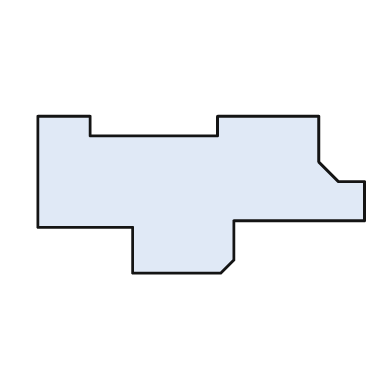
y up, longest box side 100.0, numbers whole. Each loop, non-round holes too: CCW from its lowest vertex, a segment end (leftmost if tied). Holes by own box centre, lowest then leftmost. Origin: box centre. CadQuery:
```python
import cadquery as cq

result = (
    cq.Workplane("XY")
    .moveTo(-21.0, -24.0)
    .lineTo(6.0, -24.0)
    .lineTo(10.0, -20.0)
    .lineTo(10.0, -8.0)
    .lineTo(50.0, -8.0)
    .lineTo(50.0, 4.0)
    .lineTo(42.0, 4.0)
    .lineTo(36.0, 10.0)
    .lineTo(36.0, 24.0)
    .lineTo(5.0, 24.0)
    .lineTo(5.0, 18.0)
    .lineTo(-34.0, 18.0)
    .lineTo(-34.0, 24.0)
    .lineTo(-50.0, 24.0)
    .lineTo(-50.0, -10.0)
    .lineTo(-21.0, -10.0)
    .close()
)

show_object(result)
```